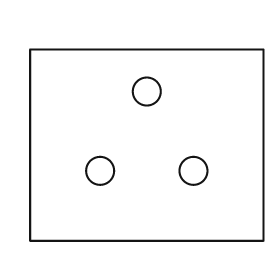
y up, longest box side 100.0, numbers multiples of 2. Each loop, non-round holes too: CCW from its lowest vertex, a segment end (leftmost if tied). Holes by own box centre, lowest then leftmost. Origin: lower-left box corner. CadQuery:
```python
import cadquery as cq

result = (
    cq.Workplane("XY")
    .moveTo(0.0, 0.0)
    .lineTo(100.0, 0.0)
    .lineTo(100.0, 82.0)
    .lineTo(0.0, 82.0)
    .close()
    .moveTo(30.0, 30.0)
    .circle(6.0)
    .moveTo(70.0, 30.0)
    .circle(6.0)
    .moveTo(50.0, 64.0)
    .circle(6.0)
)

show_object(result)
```